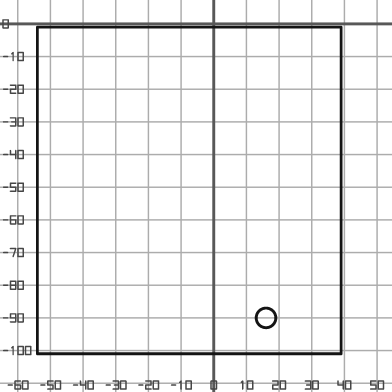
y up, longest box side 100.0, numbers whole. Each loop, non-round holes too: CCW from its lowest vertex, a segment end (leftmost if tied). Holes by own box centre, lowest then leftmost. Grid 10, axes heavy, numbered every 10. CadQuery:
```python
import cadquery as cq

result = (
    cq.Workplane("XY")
    .moveTo(-54.0, -101.0)
    .lineTo(39.0, -101.0)
    .lineTo(39.0, -1.0)
    .lineTo(-54.0, -1.0)
    .close()
    .moveTo(16.0, -90.0)
    .circle(3.0)
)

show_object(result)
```